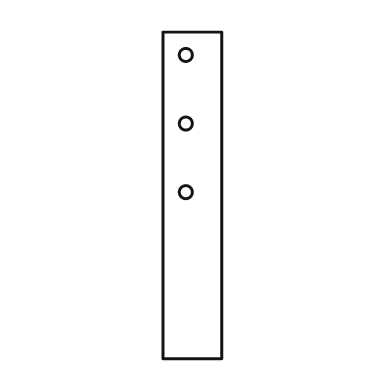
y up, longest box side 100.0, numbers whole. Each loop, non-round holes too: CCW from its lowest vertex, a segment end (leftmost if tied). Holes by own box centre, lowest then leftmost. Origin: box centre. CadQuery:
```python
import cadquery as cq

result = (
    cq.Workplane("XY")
    .moveTo(-9.0, -50.0)
    .lineTo(9.0, -50.0)
    .lineTo(9.0, 50.0)
    .lineTo(-9.0, 50.0)
    .close()
    .moveTo(-2.0, 1.0)
    .circle(2.0)
    .moveTo(-2.0, 22.0)
    .circle(2.0)
    .moveTo(-2.0, 43.0)
    .circle(2.0)
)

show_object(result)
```